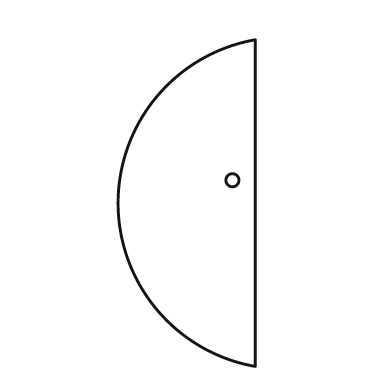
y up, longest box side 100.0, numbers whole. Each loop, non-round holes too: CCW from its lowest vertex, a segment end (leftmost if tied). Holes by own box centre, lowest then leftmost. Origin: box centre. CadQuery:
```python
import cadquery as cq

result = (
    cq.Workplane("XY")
    .moveTo(21.0, -50.0)
    .lineTo(21.0, 50.0)
    .threePointArc((-21.0, 0.0), (21.0, -50.0))
    .close()
    .moveTo(14.0, 7.0)
    .circle(2.0)
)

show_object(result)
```